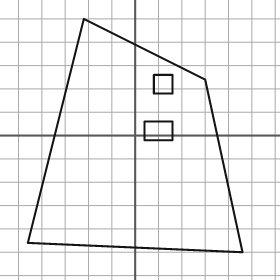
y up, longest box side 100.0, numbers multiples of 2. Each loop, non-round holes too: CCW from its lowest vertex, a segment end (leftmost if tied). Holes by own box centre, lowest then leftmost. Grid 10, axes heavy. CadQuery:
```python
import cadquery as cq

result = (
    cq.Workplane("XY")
    .moveTo(46.0, -50.0)
    .lineTo(30.0, 24.0)
    .lineTo(-22.0, 50.0)
    .lineTo(-46.0, -46.0)
    .close()
    .moveTo(4.0, -2.0)
    .lineTo(16.0, -2.0)
    .lineTo(16.0, 6.0)
    .lineTo(4.0, 6.0)
    .close()
    .moveTo(8.0, 18.0)
    .lineTo(16.0, 18.0)
    .lineTo(16.0, 26.0)
    .lineTo(8.0, 26.0)
    .close()
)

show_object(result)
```